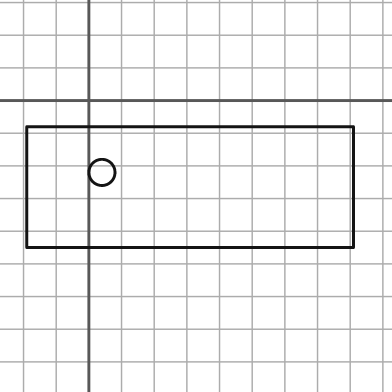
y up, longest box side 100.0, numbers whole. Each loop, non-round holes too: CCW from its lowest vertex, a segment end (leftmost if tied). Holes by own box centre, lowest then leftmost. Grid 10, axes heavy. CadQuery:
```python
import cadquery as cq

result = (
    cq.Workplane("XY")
    .moveTo(-19.0, -45.0)
    .lineTo(81.0, -45.0)
    .lineTo(81.0, -8.0)
    .lineTo(-19.0, -8.0)
    .close()
    .moveTo(4.0, -22.0)
    .circle(4.0)
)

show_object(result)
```